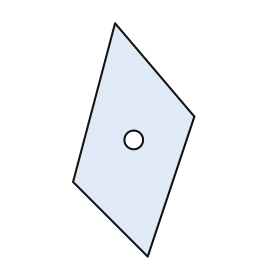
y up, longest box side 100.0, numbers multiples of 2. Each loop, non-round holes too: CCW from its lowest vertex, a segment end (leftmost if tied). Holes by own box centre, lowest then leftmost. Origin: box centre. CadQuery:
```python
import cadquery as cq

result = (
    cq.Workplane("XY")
    .moveTo(6.0, -50.0)
    .lineTo(26.0, 10.0)
    .lineTo(-8.0, 50.0)
    .lineTo(-26.0, -18.0)
    .close()
    .moveTo(0.0, 0.0)
    .circle(4.0)
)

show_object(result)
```